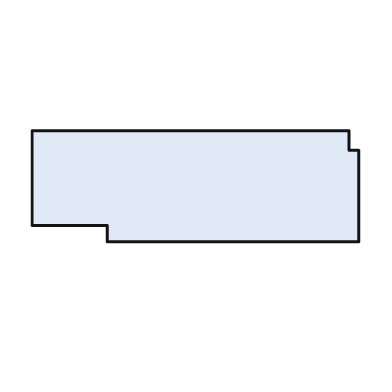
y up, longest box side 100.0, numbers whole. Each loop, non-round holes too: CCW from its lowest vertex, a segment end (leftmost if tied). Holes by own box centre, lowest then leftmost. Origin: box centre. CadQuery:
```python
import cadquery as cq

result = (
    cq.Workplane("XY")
    .moveTo(-27.0, -17.0)
    .lineTo(50.0, -17.0)
    .lineTo(50.0, 11.0)
    .lineTo(47.0, 11.0)
    .lineTo(47.0, 17.0)
    .lineTo(-50.0, 17.0)
    .lineTo(-50.0, -12.0)
    .lineTo(-27.0, -12.0)
    .close()
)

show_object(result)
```